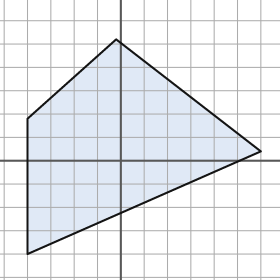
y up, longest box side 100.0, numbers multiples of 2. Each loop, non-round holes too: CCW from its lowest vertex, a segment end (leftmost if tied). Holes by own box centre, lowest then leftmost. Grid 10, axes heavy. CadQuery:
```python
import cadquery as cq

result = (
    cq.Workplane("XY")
    .moveTo(-40.0, -40.0)
    .lineTo(60.0, 4.0)
    .lineTo(-2.0, 52.0)
    .lineTo(-40.0, 18.0)
    .close()
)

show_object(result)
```